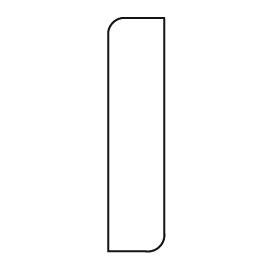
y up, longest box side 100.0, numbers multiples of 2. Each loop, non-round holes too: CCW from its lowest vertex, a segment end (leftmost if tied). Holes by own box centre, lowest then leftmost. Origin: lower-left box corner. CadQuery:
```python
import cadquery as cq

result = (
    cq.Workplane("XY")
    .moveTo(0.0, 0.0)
    .lineTo(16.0, 0.0)
    .threePointArc((22.0, 2.0), (24.0, 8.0))
    .lineTo(24.0, 100.0)
    .lineTo(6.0, 100.0)
    .threePointArc((2.0, 98.0), (0.0, 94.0))
    .close()
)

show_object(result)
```